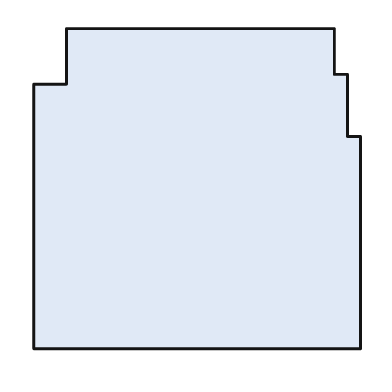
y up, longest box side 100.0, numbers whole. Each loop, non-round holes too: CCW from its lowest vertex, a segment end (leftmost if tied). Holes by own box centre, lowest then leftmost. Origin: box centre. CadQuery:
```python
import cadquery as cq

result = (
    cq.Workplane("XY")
    .moveTo(-50.0, -49.0)
    .lineTo(50.0, -49.0)
    .lineTo(50.0, 16.0)
    .lineTo(46.0, 16.0)
    .lineTo(46.0, 35.0)
    .lineTo(42.0, 35.0)
    .lineTo(42.0, 49.0)
    .lineTo(-40.0, 49.0)
    .lineTo(-40.0, 32.0)
    .lineTo(-50.0, 32.0)
    .close()
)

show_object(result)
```